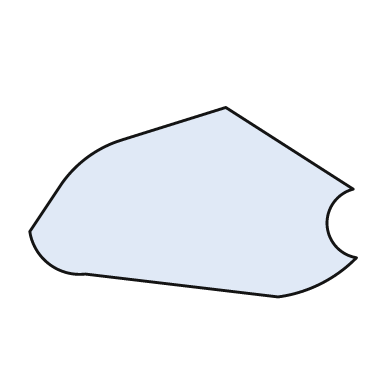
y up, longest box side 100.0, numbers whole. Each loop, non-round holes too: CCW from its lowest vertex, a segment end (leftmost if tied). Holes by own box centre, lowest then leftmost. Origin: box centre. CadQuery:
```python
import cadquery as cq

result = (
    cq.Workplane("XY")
    .moveTo(26.0, -29.0)
    .threePointArc((39.0, -25.0), (50.0, -17.0))
    .threePointArc((41.0, -7.0), (49.0, 4.0))
    .lineTo(10.0, 29.0)
    .lineTo(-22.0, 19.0)
    .threePointArc((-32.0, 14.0), (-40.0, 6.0))
    .lineTo(-50.0, -9.0)
    .threePointArc((-44.0, -19.0), (-33.0, -22.0))
    .close()
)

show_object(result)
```